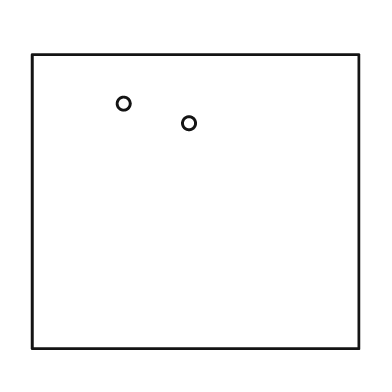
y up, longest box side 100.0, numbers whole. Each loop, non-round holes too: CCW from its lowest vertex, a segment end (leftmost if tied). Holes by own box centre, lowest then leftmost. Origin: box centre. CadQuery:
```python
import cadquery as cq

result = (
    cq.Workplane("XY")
    .moveTo(-50.0, -45.0)
    .lineTo(50.0, -45.0)
    .lineTo(50.0, 45.0)
    .lineTo(-50.0, 45.0)
    .close()
    .moveTo(-2.0, 24.0)
    .circle(2.0)
    .moveTo(-22.0, 30.0)
    .circle(2.0)
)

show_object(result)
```